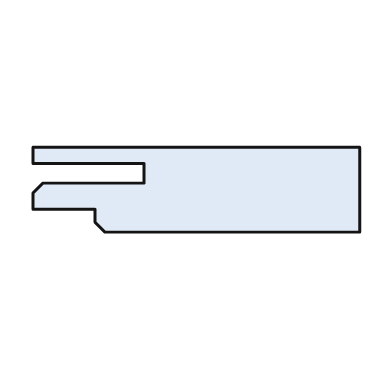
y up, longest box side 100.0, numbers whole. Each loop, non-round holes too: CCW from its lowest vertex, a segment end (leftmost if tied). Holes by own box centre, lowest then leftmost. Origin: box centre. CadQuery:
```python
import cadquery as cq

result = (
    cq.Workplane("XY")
    .moveTo(-28.0, -13.0)
    .lineTo(50.0, -13.0)
    .lineTo(50.0, 13.0)
    .lineTo(-50.0, 13.0)
    .lineTo(-50.0, 8.0)
    .lineTo(-16.0, 8.0)
    .lineTo(-16.0, 2.0)
    .lineTo(-47.0, 2.0)
    .lineTo(-50.0, -1.0)
    .lineTo(-50.0, -6.0)
    .lineTo(-31.0, -6.0)
    .lineTo(-31.0, -10.0)
    .close()
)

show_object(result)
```